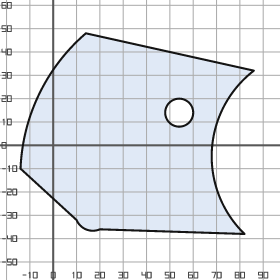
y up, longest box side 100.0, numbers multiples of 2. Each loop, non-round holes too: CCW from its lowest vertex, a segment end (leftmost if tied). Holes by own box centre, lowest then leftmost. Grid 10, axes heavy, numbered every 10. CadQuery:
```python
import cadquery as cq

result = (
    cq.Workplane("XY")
    .moveTo(82.0, -38.0)
    .threePointArc((68.0, -2.0), (86.0, 32.0))
    .lineTo(14.0, 48.0)
    .threePointArc((-6.0, 22.0), (-14.0, -10.0))
    .lineTo(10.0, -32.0)
    .threePointArc((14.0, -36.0), (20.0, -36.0))
    .close()
    .moveTo(54.0, 14.0)
    .circle(6.0)
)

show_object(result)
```